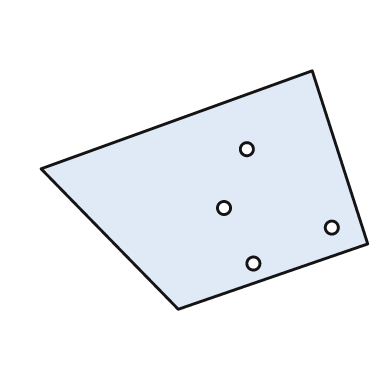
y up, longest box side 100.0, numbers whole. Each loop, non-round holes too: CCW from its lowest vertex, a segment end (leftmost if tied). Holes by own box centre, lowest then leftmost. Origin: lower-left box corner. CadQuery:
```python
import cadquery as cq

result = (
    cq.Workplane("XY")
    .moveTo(42.0, 0.0)
    .lineTo(100.0, 20.0)
    .lineTo(83.0, 73.0)
    .lineTo(0.0, 43.0)
    .close()
    .moveTo(65.0, 14.0)
    .circle(2.0)
    .moveTo(89.0, 25.0)
    .circle(2.0)
    .moveTo(56.0, 31.0)
    .circle(2.0)
    .moveTo(63.0, 49.0)
    .circle(2.0)
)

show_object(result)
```